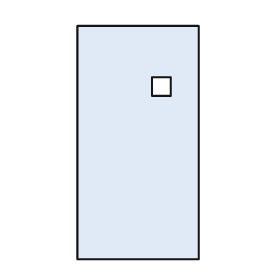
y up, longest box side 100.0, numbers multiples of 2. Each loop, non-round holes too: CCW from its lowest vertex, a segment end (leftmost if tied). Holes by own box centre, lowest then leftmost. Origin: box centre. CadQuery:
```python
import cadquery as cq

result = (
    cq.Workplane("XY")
    .moveTo(-26.0, -50.0)
    .lineTo(26.0, -50.0)
    .lineTo(26.0, 50.0)
    .lineTo(-26.0, 50.0)
    .close()
    .moveTo(6.0, 20.0)
    .lineTo(14.0, 20.0)
    .lineTo(14.0, 28.0)
    .lineTo(6.0, 28.0)
    .close()
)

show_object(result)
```